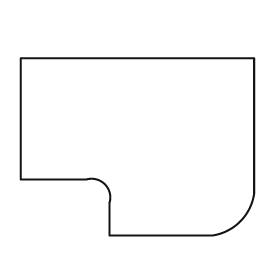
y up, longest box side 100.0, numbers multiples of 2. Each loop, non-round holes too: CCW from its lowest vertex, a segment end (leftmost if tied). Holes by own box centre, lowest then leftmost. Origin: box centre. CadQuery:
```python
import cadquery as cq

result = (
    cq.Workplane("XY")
    .moveTo(-12.0, -38.0)
    .lineTo(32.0, -38.0)
    .threePointArc((44.0, -32.0), (50.0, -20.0))
    .lineTo(50.0, 38.0)
    .lineTo(-50.0, 38.0)
    .lineTo(-50.0, -14.0)
    .lineTo(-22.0, -14.0)
    .threePointArc((-14.0, -16.0), (-12.0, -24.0))
    .close()
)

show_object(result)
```